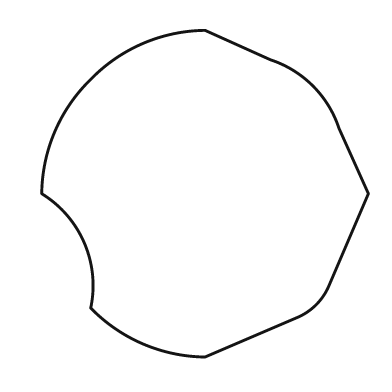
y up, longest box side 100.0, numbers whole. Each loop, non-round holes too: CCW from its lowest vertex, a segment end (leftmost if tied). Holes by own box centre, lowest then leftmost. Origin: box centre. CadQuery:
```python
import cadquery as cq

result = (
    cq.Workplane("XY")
    .moveTo(0.0, -50.0)
    .lineTo(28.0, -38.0)
    .threePointArc((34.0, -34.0), (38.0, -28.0))
    .lineTo(50.0, 0.0)
    .lineTo(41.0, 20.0)
    .threePointArc((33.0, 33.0), (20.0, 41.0))
    .lineTo(0.0, 50.0)
    .threePointArc((-19.0, 46.0), (-35.0, 35.0))
    .threePointArc((-46.0, 19.0), (-50.0, 0.0))
    .threePointArc((-37.0, -15.0), (-35.0, -35.0))
    .threePointArc((-19.0, -46.0), (0.0, -50.0))
    .close()
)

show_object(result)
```